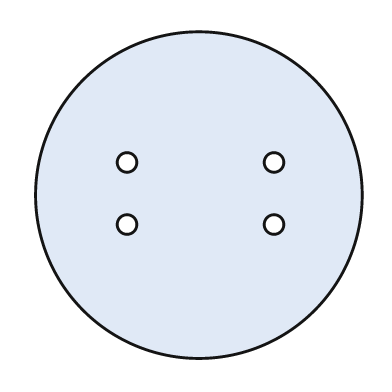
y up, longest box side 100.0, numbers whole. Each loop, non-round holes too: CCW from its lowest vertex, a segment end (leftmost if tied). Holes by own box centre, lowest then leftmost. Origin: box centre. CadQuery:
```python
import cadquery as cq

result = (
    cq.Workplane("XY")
    .moveTo(0.0, 0.0)
    .circle(50.0)
    .moveTo(-22.0, -9.0)
    .circle(3.0)
    .moveTo(23.0, -9.0)
    .circle(3.0)
    .moveTo(-22.0, 10.0)
    .circle(3.0)
    .moveTo(23.0, 10.0)
    .circle(3.0)
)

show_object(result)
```